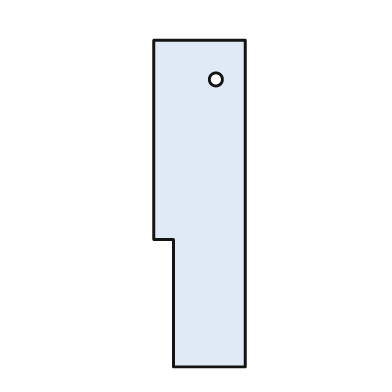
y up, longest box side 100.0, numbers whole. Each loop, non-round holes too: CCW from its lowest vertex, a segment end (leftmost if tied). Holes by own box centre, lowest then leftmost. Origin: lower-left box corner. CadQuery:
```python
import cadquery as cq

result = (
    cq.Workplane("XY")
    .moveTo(6.0, 0.0)
    .lineTo(28.0, 0.0)
    .lineTo(28.0, 100.0)
    .lineTo(0.0, 100.0)
    .lineTo(0.0, 39.0)
    .lineTo(6.0, 39.0)
    .close()
    .moveTo(19.0, 88.0)
    .circle(2.0)
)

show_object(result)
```